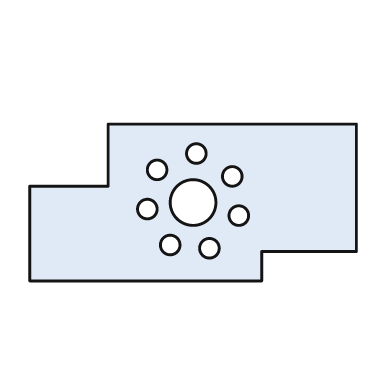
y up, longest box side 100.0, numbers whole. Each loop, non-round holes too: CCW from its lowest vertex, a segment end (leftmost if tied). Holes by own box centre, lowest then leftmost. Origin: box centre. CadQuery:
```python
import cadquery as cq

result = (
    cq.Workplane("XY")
    .moveTo(-50.0, -24.0)
    .lineTo(21.0, -24.0)
    .lineTo(21.0, -15.0)
    .lineTo(50.0, -15.0)
    .lineTo(50.0, 24.0)
    .lineTo(-26.0, 24.0)
    .lineTo(-26.0, 5.0)
    .lineTo(-50.0, 5.0)
    .close()
    .moveTo(5.0, -14.0)
    .circle(3.0)
    .moveTo(-7.0, -13.0)
    .circle(3.0)
    .moveTo(14.0, -4.0)
    .circle(3.0)
    .moveTo(-14.0, -2.0)
    .circle(3.0)
    .moveTo(0.0, 0.0)
    .circle(7.0)
    .moveTo(12.0, 8.0)
    .circle(3.0)
    .moveTo(-11.0, 10.0)
    .circle(3.0)
    .moveTo(1.0, 15.0)
    .circle(3.0)
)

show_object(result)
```